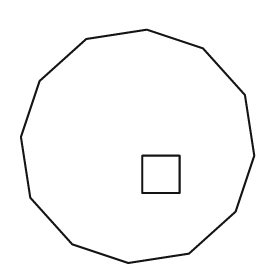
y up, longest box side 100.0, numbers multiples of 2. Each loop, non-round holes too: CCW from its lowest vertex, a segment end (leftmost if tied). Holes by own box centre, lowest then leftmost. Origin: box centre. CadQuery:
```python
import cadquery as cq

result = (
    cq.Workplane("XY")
    .moveTo(-4.0, -50.0)
    .lineTo(22.0, -46.0)
    .lineTo(42.0, -28.0)
    .lineTo(50.0, -4.0)
    .lineTo(46.0, 22.0)
    .lineTo(28.0, 42.0)
    .lineTo(4.0, 50.0)
    .lineTo(-22.0, 46.0)
    .lineTo(-42.0, 28.0)
    .lineTo(-50.0, 4.0)
    .lineTo(-46.0, -22.0)
    .lineTo(-28.0, -42.0)
    .close()
    .moveTo(2.0, -20.0)
    .lineTo(18.0, -20.0)
    .lineTo(18.0, -4.0)
    .lineTo(2.0, -4.0)
    .close()
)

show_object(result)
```